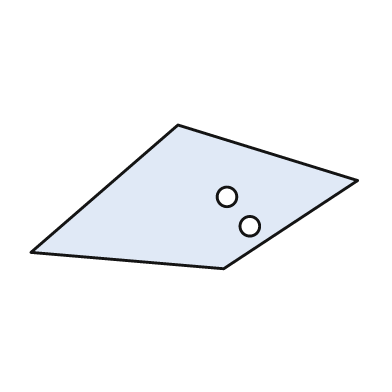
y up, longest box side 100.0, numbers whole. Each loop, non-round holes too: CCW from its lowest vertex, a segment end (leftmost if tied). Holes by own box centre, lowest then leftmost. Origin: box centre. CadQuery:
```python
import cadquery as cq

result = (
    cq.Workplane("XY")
    .moveTo(9.0, -22.0)
    .lineTo(50.0, 5.0)
    .lineTo(-5.0, 22.0)
    .lineTo(-50.0, -17.0)
    .close()
    .moveTo(17.0, -9.0)
    .circle(3.0)
    .moveTo(10.0, 0.0)
    .circle(3.0)
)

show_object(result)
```